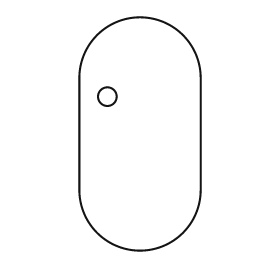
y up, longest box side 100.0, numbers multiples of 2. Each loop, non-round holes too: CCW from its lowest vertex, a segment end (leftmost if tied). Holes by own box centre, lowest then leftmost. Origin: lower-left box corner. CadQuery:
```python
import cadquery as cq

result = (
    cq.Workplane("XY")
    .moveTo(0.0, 26.0)
    .threePointArc((26.0, 0.0), (52.0, 26.0))
    .lineTo(52.0, 74.0)
    .threePointArc((26.0, 100.0), (0.0, 74.0))
    .close()
    .moveTo(12.0, 66.0)
    .circle(4.0)
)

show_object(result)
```